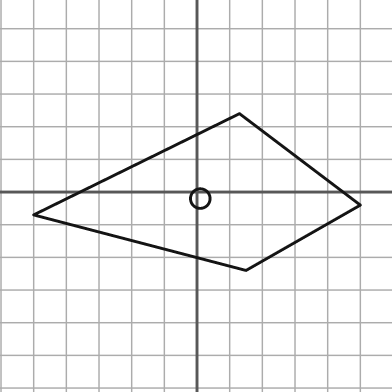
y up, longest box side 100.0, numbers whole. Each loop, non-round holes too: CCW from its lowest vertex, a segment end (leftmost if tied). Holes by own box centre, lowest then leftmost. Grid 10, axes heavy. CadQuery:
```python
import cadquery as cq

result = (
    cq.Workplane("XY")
    .moveTo(15.0, -24.0)
    .lineTo(50.0, -4.0)
    .lineTo(13.0, 24.0)
    .lineTo(-50.0, -7.0)
    .close()
    .moveTo(1.0, -2.0)
    .circle(3.0)
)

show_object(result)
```